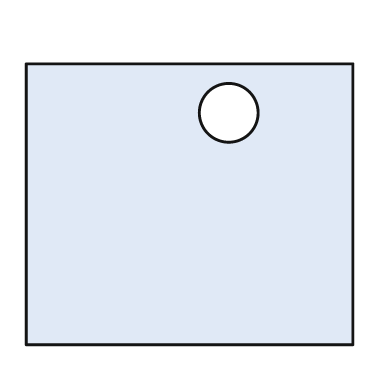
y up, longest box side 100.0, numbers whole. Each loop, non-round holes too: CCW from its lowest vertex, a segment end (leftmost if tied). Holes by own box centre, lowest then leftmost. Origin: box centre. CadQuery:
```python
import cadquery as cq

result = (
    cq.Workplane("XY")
    .moveTo(-50.0, -43.0)
    .lineTo(50.0, -43.0)
    .lineTo(50.0, 43.0)
    .lineTo(-50.0, 43.0)
    .close()
    .moveTo(12.0, 28.0)
    .circle(9.0)
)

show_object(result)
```